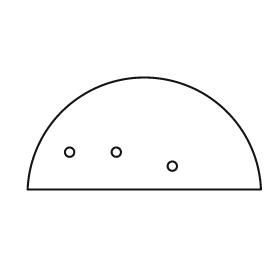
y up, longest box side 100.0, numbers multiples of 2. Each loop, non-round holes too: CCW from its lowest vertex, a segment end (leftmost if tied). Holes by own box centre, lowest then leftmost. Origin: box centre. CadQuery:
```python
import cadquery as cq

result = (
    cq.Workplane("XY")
    .moveTo(-50.0, -24.0)
    .lineTo(50.0, -24.0)
    .threePointArc((0.0, 24.0), (-50.0, -24.0))
    .close()
    .moveTo(12.0, -14.0)
    .circle(2.0)
    .moveTo(-32.0, -8.0)
    .circle(2.0)
    .moveTo(-12.0, -8.0)
    .circle(2.0)
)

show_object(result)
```